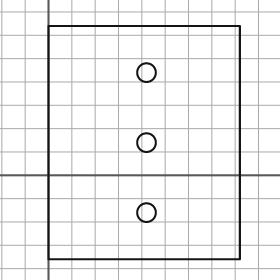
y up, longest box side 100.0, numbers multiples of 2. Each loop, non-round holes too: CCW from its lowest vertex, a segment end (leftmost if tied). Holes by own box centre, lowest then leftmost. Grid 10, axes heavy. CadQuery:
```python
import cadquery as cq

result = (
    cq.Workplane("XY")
    .moveTo(0.0, -36.0)
    .lineTo(82.0, -36.0)
    .lineTo(82.0, 64.0)
    .lineTo(0.0, 64.0)
    .close()
    .moveTo(42.0, -16.0)
    .circle(4.0)
    .moveTo(42.0, 14.0)
    .circle(4.0)
    .moveTo(42.0, 44.0)
    .circle(4.0)
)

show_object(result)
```